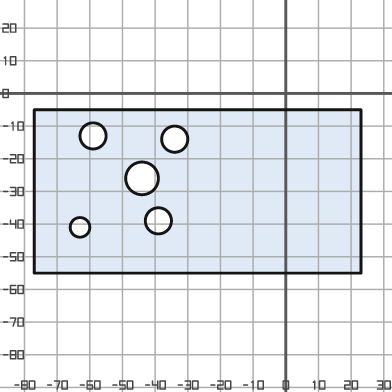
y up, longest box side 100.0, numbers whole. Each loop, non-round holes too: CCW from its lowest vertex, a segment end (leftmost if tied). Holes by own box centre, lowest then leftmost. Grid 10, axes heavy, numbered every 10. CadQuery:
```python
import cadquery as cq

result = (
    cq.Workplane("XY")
    .moveTo(-77.0, -55.0)
    .lineTo(23.0, -55.0)
    .lineTo(23.0, -5.0)
    .lineTo(-77.0, -5.0)
    .close()
    .moveTo(-63.0, -41.0)
    .circle(3.0)
    .moveTo(-39.0, -39.0)
    .circle(4.0)
    .moveTo(-44.0, -26.0)
    .circle(5.0)
    .moveTo(-34.0, -14.0)
    .circle(4.0)
    .moveTo(-59.0, -13.0)
    .circle(4.0)
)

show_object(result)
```